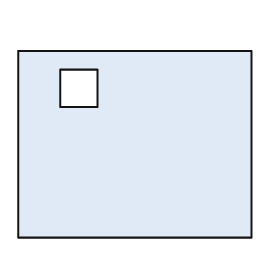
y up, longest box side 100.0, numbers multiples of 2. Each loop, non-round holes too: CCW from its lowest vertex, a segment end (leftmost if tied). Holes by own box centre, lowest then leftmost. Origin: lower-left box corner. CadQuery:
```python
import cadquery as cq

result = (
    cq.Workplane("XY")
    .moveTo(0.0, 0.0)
    .lineTo(100.0, 0.0)
    .lineTo(100.0, 80.0)
    .lineTo(0.0, 80.0)
    .close()
    .moveTo(18.0, 56.0)
    .lineTo(34.0, 56.0)
    .lineTo(34.0, 72.0)
    .lineTo(18.0, 72.0)
    .close()
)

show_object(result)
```